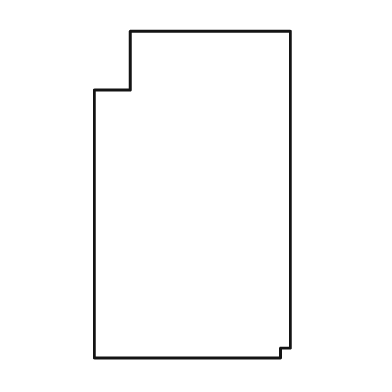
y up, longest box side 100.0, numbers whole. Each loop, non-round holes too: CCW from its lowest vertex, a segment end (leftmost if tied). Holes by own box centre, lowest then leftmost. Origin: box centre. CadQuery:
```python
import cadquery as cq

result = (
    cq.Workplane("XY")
    .moveTo(-30.0, -50.0)
    .lineTo(27.0, -50.0)
    .lineTo(27.0, -47.0)
    .lineTo(30.0, -47.0)
    .lineTo(30.0, 50.0)
    .lineTo(-19.0, 50.0)
    .lineTo(-19.0, 32.0)
    .lineTo(-30.0, 32.0)
    .close()
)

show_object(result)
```